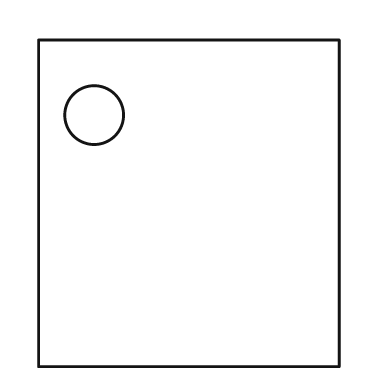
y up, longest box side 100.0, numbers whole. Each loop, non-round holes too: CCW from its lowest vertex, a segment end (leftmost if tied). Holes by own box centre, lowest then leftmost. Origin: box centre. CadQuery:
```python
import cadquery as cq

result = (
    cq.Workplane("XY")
    .moveTo(-46.0, -50.0)
    .lineTo(46.0, -50.0)
    .lineTo(46.0, 50.0)
    .lineTo(-46.0, 50.0)
    .close()
    .moveTo(-29.0, 27.0)
    .circle(9.0)
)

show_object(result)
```